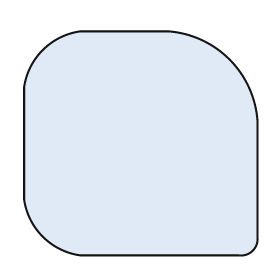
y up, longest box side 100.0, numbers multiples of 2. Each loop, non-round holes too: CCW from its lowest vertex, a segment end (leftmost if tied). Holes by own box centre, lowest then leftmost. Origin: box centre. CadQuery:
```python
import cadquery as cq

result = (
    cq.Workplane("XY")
    .moveTo(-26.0, -48.0)
    .lineTo(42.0, -48.0)
    .threePointArc((48.0, -46.0), (50.0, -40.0))
    .lineTo(50.0, 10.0)
    .threePointArc((38.0, 36.0), (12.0, 48.0))
    .lineTo(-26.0, 48.0)
    .threePointArc((-42.0, 40.0), (-50.0, 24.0))
    .lineTo(-50.0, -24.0)
    .threePointArc((-42.0, -40.0), (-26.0, -48.0))
    .close()
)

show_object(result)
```